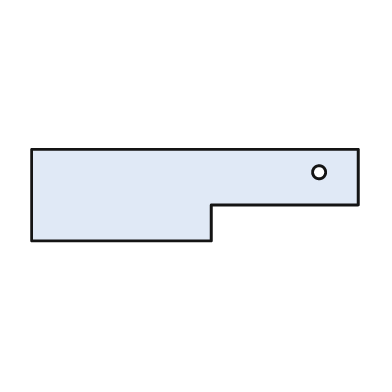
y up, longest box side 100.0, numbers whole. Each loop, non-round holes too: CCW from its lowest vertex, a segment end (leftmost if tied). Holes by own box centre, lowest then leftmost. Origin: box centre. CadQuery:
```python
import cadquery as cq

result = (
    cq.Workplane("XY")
    .moveTo(-50.0, -14.0)
    .lineTo(5.0, -14.0)
    .lineTo(5.0, -3.0)
    .lineTo(50.0, -3.0)
    .lineTo(50.0, 14.0)
    .lineTo(-50.0, 14.0)
    .close()
    .moveTo(38.0, 7.0)
    .circle(2.0)
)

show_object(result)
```